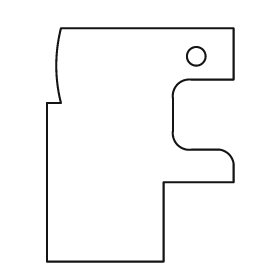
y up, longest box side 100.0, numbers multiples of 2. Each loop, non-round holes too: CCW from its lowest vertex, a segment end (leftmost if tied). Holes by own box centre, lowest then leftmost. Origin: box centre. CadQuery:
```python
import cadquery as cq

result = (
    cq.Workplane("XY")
    .moveTo(-40.0, -50.0)
    .lineTo(10.0, -50.0)
    .lineTo(10.0, -16.0)
    .lineTo(40.0, -16.0)
    .lineTo(40.0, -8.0)
    .threePointArc((38.0, -4.0), (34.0, -2.0))
    .lineTo(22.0, -2.0)
    .threePointArc((16.0, 0.0), (14.0, 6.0))
    .lineTo(14.0, 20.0)
    .threePointArc((16.0, 26.0), (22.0, 28.0))
    .lineTo(40.0, 28.0)
    .lineTo(40.0, 50.0)
    .lineTo(-34.0, 50.0)
    .threePointArc((-36.0, 34.0), (-34.0, 18.0))
    .lineTo(-40.0, 18.0)
    .close()
    .moveTo(24.0, 38.0)
    .circle(4.0)
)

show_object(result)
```